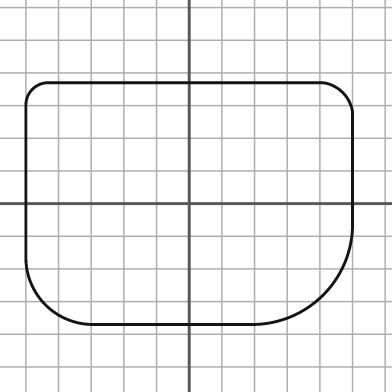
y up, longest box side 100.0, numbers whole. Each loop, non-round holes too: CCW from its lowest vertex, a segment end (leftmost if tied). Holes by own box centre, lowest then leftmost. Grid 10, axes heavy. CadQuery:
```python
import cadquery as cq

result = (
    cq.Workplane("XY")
    .moveTo(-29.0, -37.0)
    .lineTo(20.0, -37.0)
    .threePointArc((41.0, -28.0), (50.0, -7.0))
    .lineTo(50.0, 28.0)
    .threePointArc((47.0, 34.0), (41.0, 37.0))
    .lineTo(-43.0, 37.0)
    .threePointArc((-48.0, 35.0), (-50.0, 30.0))
    .lineTo(-50.0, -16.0)
    .threePointArc((-44.0, -31.0), (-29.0, -37.0))
    .close()
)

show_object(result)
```